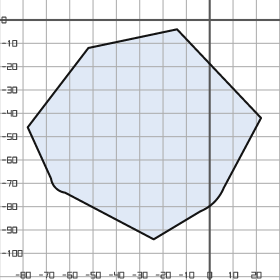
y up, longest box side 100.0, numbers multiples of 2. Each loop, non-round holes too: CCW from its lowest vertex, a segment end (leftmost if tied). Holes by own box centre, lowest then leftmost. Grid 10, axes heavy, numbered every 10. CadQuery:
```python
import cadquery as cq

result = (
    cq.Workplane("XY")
    .moveTo(-24.0, -94.0)
    .lineTo(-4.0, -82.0)
    .threePointArc((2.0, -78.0), (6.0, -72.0))
    .lineTo(22.0, -42.0)
    .lineTo(-14.0, -4.0)
    .lineTo(-52.0, -12.0)
    .lineTo(-78.0, -46.0)
    .lineTo(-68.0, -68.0)
    .threePointArc((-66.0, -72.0), (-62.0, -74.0))
    .close()
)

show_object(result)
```